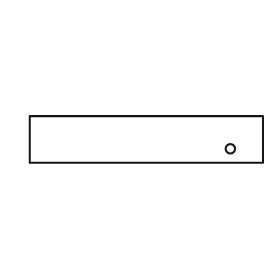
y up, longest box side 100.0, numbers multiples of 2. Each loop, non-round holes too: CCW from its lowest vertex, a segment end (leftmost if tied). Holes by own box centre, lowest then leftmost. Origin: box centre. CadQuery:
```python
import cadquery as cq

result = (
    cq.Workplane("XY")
    .moveTo(-50.0, -10.0)
    .lineTo(50.0, -10.0)
    .lineTo(50.0, 10.0)
    .lineTo(-50.0, 10.0)
    .close()
    .moveTo(36.0, -4.0)
    .circle(2.0)
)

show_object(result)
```